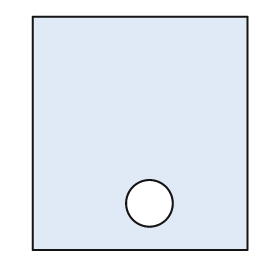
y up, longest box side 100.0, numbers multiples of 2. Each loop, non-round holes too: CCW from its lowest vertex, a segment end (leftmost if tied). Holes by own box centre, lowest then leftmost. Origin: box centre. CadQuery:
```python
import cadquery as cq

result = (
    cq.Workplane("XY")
    .moveTo(-46.0, -50.0)
    .lineTo(46.0, -50.0)
    .lineTo(46.0, 50.0)
    .lineTo(-46.0, 50.0)
    .close()
    .moveTo(4.0, -30.0)
    .circle(10.0)
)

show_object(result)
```